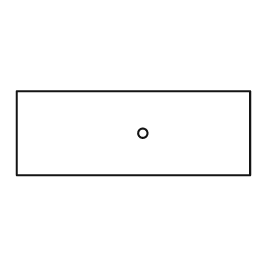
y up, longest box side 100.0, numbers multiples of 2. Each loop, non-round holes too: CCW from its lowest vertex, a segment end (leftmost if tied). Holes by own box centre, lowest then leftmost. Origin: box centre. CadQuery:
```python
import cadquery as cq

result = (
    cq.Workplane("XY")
    .moveTo(-50.0, -18.0)
    .lineTo(50.0, -18.0)
    .lineTo(50.0, 18.0)
    .lineTo(-50.0, 18.0)
    .close()
    .moveTo(4.0, 0.0)
    .circle(2.0)
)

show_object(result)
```